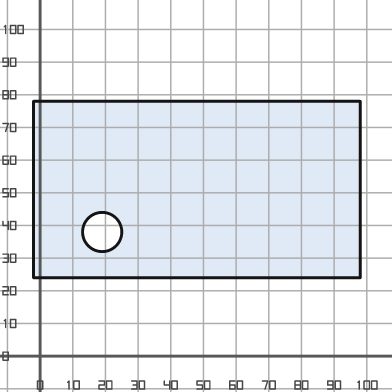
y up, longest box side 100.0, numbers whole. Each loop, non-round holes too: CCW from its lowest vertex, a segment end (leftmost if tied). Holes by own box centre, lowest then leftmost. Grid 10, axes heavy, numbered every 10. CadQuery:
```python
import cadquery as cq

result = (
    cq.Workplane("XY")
    .moveTo(-2.0, 24.0)
    .lineTo(98.0, 24.0)
    .lineTo(98.0, 78.0)
    .lineTo(-2.0, 78.0)
    .close()
    .moveTo(19.0, 38.0)
    .circle(6.0)
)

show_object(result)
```